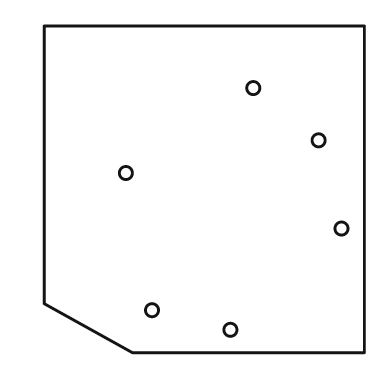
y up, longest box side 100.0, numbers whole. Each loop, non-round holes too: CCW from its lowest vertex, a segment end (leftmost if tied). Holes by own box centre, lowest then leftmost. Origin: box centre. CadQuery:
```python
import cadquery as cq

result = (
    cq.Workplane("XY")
    .moveTo(-22.0, -50.0)
    .lineTo(49.0, -50.0)
    .lineTo(49.0, 50.0)
    .lineTo(-49.0, 50.0)
    .lineTo(-49.0, -35.0)
    .close()
    .moveTo(8.0, -43.0)
    .circle(2.0)
    .moveTo(-16.0, -37.0)
    .circle(2.0)
    .moveTo(42.0, -12.0)
    .circle(2.0)
    .moveTo(-24.0, 5.0)
    .circle(2.0)
    .moveTo(35.0, 15.0)
    .circle(2.0)
    .moveTo(15.0, 31.0)
    .circle(2.0)
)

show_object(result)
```